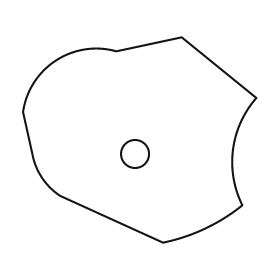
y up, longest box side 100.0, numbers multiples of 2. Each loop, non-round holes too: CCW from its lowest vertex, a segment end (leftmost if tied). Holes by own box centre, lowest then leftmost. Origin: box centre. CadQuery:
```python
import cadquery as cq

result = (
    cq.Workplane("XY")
    .moveTo(10.0, -44.0)
    .threePointArc((28.0, -38.0), (44.0, -28.0))
    .threePointArc((40.0, -4.0), (50.0, 18.0))
    .lineTo(18.0, 44.0)
    .lineTo(-10.0, 38.0)
    .threePointArc((-36.0, 34.0), (-50.0, 12.0))
    .lineTo(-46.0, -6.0)
    .threePointArc((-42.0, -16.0), (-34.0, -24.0))
    .close()
    .moveTo(-2.0, -6.0)
    .circle(6.0)
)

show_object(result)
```